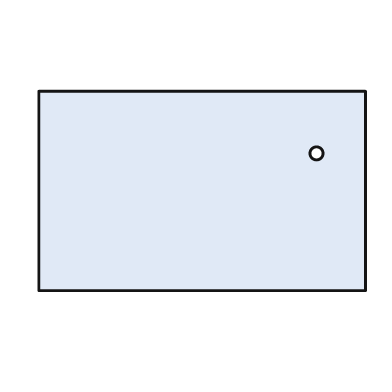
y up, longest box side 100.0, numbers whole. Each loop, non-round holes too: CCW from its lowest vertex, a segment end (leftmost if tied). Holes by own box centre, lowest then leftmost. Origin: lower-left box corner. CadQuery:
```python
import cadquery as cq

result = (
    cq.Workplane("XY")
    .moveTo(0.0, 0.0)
    .lineTo(100.0, 0.0)
    .lineTo(100.0, 61.0)
    .lineTo(0.0, 61.0)
    .close()
    .moveTo(85.0, 42.0)
    .circle(2.0)
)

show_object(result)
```